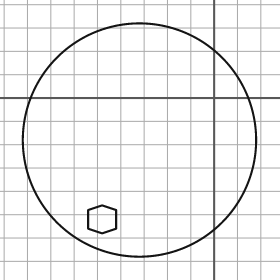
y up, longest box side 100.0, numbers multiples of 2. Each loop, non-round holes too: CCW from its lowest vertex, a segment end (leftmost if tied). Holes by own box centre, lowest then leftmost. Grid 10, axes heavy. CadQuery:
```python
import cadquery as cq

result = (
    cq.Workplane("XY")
    .moveTo(-32.0, -18.0)
    .circle(50.0)
    .moveTo(-48.0, -58.0)
    .lineTo(-42.0, -56.0)
    .lineTo(-42.0, -48.0)
    .lineTo(-48.0, -46.0)
    .lineTo(-54.0, -48.0)
    .lineTo(-54.0, -56.0)
    .close()
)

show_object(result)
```